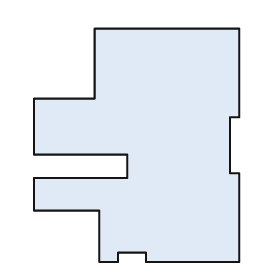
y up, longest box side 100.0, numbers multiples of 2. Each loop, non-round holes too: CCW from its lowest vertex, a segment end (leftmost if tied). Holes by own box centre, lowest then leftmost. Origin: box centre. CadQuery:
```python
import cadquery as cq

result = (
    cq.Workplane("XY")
    .moveTo(-16.0, -50.0)
    .lineTo(-8.0, -50.0)
    .lineTo(-8.0, -46.0)
    .lineTo(4.0, -46.0)
    .lineTo(4.0, -50.0)
    .lineTo(44.0, -50.0)
    .lineTo(44.0, -12.0)
    .lineTo(40.0, -12.0)
    .lineTo(40.0, 12.0)
    .lineTo(44.0, 12.0)
    .lineTo(44.0, 50.0)
    .lineTo(-18.0, 50.0)
    .lineTo(-18.0, 20.0)
    .lineTo(-44.0, 20.0)
    .lineTo(-44.0, -4.0)
    .lineTo(-4.0, -4.0)
    .lineTo(-4.0, -14.0)
    .lineTo(-44.0, -14.0)
    .lineTo(-44.0, -28.0)
    .lineTo(-16.0, -28.0)
    .close()
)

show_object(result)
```